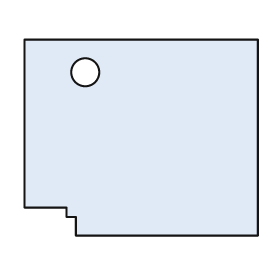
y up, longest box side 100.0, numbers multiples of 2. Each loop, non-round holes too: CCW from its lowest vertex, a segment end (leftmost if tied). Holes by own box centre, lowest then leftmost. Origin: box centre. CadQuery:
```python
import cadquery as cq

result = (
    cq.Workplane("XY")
    .moveTo(-28.0, -42.0)
    .lineTo(50.0, -42.0)
    .lineTo(50.0, 42.0)
    .lineTo(-50.0, 42.0)
    .lineTo(-50.0, -30.0)
    .lineTo(-32.0, -30.0)
    .lineTo(-32.0, -34.0)
    .lineTo(-28.0, -34.0)
    .close()
    .moveTo(-24.0, 28.0)
    .circle(6.0)
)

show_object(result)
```